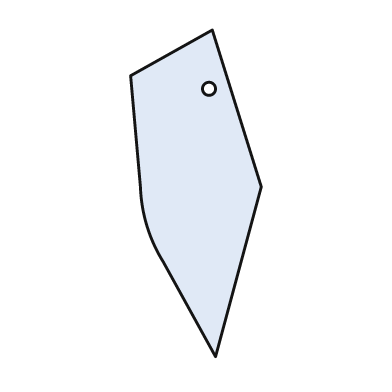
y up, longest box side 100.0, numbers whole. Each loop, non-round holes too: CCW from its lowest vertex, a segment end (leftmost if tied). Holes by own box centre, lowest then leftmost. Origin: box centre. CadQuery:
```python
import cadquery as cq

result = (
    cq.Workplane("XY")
    .moveTo(6.0, -50.0)
    .lineTo(20.0, 2.0)
    .lineTo(5.0, 50.0)
    .lineTo(-20.0, 36.0)
    .lineTo(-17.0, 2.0)
    .threePointArc((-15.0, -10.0), (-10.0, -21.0))
    .close()
    .moveTo(4.0, 32.0)
    .circle(2.0)
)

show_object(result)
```